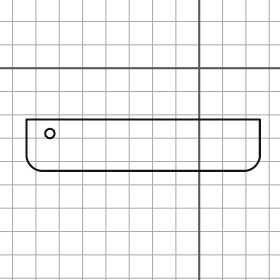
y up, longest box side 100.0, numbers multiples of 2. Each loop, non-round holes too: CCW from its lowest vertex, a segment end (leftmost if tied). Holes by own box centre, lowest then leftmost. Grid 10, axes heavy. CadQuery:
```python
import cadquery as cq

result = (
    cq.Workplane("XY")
    .moveTo(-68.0, -44.0)
    .lineTo(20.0, -44.0)
    .threePointArc((24.0, -42.0), (26.0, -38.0))
    .lineTo(26.0, -22.0)
    .lineTo(-74.0, -22.0)
    .lineTo(-74.0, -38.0)
    .threePointArc((-72.0, -42.0), (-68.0, -44.0))
    .close()
    .moveTo(-64.0, -28.0)
    .circle(2.0)
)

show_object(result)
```